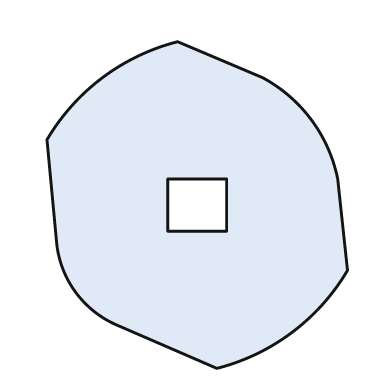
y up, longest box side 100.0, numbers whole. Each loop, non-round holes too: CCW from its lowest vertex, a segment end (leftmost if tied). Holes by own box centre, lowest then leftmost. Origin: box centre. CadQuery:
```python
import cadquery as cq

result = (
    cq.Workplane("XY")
    .moveTo(6.0, -50.0)
    .threePointArc((29.0, -39.0), (46.0, -20.0))
    .lineTo(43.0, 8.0)
    .threePointArc((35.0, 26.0), (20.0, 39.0))
    .lineTo(-6.0, 50.0)
    .threePointArc((-29.0, 39.0), (-46.0, 20.0))
    .lineTo(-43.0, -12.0)
    .threePointArc((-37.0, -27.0), (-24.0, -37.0))
    .close()
    .moveTo(-9.0, -8.0)
    .lineTo(9.0, -8.0)
    .lineTo(9.0, 8.0)
    .lineTo(-9.0, 8.0)
    .close()
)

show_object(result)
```